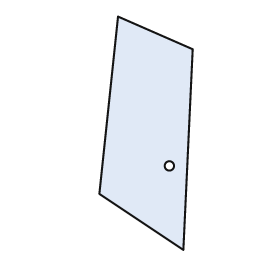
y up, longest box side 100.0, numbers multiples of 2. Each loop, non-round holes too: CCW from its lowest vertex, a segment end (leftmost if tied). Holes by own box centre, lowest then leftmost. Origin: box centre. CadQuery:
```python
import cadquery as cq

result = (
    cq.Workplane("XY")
    .moveTo(16.0, -50.0)
    .lineTo(20.0, 36.0)
    .lineTo(-12.0, 50.0)
    .lineTo(-20.0, -26.0)
    .close()
    .moveTo(10.0, -14.0)
    .circle(2.0)
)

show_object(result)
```